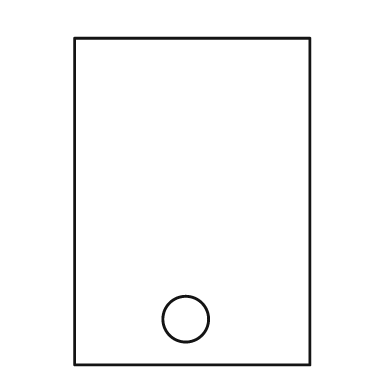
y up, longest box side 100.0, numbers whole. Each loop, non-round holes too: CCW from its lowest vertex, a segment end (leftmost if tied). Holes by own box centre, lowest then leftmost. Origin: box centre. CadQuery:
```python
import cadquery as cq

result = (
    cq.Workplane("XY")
    .moveTo(-36.0, -50.0)
    .lineTo(36.0, -50.0)
    .lineTo(36.0, 50.0)
    .lineTo(-36.0, 50.0)
    .close()
    .moveTo(-2.0, -36.0)
    .circle(7.0)
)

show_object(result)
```